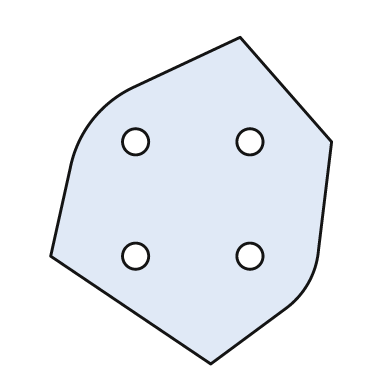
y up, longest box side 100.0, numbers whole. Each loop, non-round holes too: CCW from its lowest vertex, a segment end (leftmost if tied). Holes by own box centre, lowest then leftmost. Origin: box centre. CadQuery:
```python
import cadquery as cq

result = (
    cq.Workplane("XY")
    .moveTo(6.0, -50.0)
    .lineTo(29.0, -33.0)
    .threePointArc((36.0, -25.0), (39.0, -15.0))
    .lineTo(43.0, 18.0)
    .lineTo(15.0, 50.0)
    .lineTo(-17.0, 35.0)
    .threePointArc((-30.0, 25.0), (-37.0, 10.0))
    .lineTo(-43.0, -17.0)
    .close()
    .moveTo(-17.0, -17.0)
    .circle(4.0)
    .moveTo(18.0, -17.0)
    .circle(4.0)
    .moveTo(-17.0, 18.0)
    .circle(4.0)
    .moveTo(18.0, 18.0)
    .circle(4.0)
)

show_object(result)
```